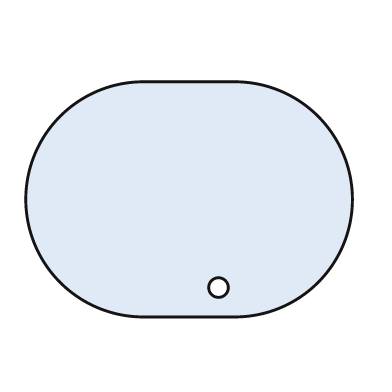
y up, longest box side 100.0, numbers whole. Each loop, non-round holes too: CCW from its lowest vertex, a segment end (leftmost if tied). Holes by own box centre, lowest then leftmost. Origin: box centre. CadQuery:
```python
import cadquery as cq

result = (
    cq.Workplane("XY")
    .moveTo(-14.0, -36.0)
    .lineTo(14.0, -36.0)
    .threePointArc((50.0, 0.0), (14.0, 36.0))
    .lineTo(-14.0, 36.0)
    .threePointArc((-50.0, 0.0), (-14.0, -36.0))
    .close()
    .moveTo(9.0, -27.0)
    .circle(3.0)
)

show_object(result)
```